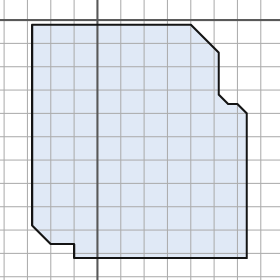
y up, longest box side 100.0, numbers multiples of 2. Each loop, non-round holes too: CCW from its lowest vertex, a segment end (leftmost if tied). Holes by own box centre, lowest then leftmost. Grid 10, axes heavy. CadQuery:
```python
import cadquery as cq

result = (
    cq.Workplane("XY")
    .moveTo(-10.0, -102.0)
    .lineTo(64.0, -102.0)
    .lineTo(64.0, -40.0)
    .lineTo(60.0, -36.0)
    .lineTo(56.0, -36.0)
    .lineTo(52.0, -32.0)
    .lineTo(52.0, -14.0)
    .lineTo(40.0, -2.0)
    .lineTo(-28.0, -2.0)
    .lineTo(-28.0, -88.0)
    .lineTo(-20.0, -96.0)
    .lineTo(-10.0, -96.0)
    .close()
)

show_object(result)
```